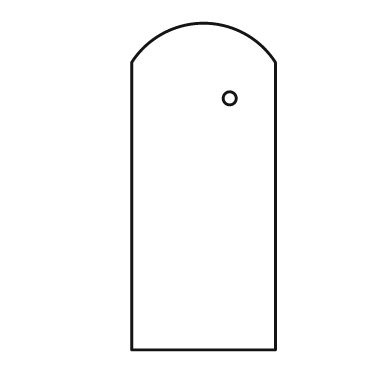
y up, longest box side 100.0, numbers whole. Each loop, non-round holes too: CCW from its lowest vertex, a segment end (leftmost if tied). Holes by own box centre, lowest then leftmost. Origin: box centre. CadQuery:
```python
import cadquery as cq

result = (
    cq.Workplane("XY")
    .moveTo(-22.0, -50.0)
    .lineTo(22.0, -50.0)
    .lineTo(22.0, 38.0)
    .threePointArc((0.0, 50.0), (-22.0, 38.0))
    .close()
    .moveTo(8.0, 27.0)
    .circle(2.0)
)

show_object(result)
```